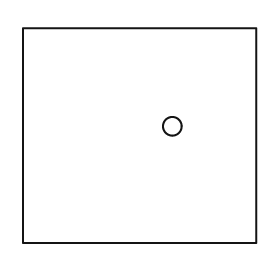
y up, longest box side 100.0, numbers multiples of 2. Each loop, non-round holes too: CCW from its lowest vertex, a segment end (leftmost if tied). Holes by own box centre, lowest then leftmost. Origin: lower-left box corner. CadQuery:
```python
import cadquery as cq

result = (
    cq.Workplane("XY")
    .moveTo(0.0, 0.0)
    .lineTo(100.0, 0.0)
    .lineTo(100.0, 92.0)
    .lineTo(0.0, 92.0)
    .close()
    .moveTo(64.0, 50.0)
    .circle(4.0)
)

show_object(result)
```